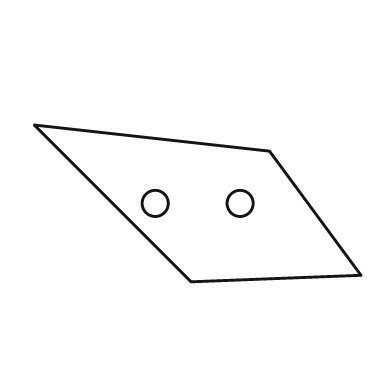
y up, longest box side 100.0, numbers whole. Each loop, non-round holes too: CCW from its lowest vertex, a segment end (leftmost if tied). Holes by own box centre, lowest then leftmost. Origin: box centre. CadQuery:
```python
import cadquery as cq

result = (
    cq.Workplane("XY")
    .moveTo(-2.0, -24.0)
    .lineTo(50.0, -22.0)
    .lineTo(22.0, 16.0)
    .lineTo(-50.0, 24.0)
    .close()
    .moveTo(-13.0, 0.0)
    .circle(4.0)
    .moveTo(13.0, 0.0)
    .circle(4.0)
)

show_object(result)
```